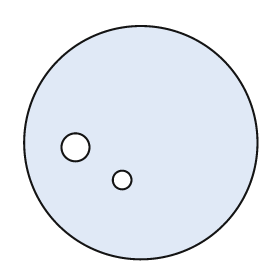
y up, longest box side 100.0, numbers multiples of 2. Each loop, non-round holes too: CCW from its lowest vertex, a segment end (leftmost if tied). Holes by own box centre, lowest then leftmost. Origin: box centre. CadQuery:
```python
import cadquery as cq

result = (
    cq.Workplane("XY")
    .moveTo(0.0, 0.0)
    .circle(50.0)
    .moveTo(-8.0, -16.0)
    .circle(4.0)
    .moveTo(-28.0, -2.0)
    .circle(6.0)
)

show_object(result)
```